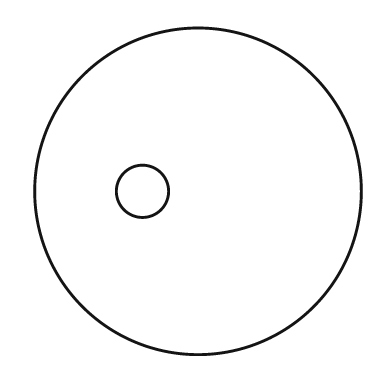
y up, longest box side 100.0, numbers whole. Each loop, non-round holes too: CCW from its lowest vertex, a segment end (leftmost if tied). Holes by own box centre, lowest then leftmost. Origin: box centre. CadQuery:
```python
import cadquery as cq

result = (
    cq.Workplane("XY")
    .moveTo(0.0, 0.0)
    .circle(50.0)
    .moveTo(-17.0, 0.0)
    .circle(8.0)
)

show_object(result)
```